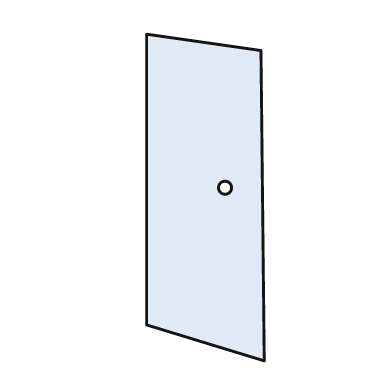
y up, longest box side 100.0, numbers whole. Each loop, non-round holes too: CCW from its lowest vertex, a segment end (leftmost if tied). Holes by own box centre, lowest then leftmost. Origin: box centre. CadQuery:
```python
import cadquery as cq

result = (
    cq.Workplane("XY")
    .moveTo(18.0, -50.0)
    .lineTo(17.0, 45.0)
    .lineTo(-18.0, 50.0)
    .lineTo(-18.0, -39.0)
    .close()
    .moveTo(6.0, 3.0)
    .circle(2.0)
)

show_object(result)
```